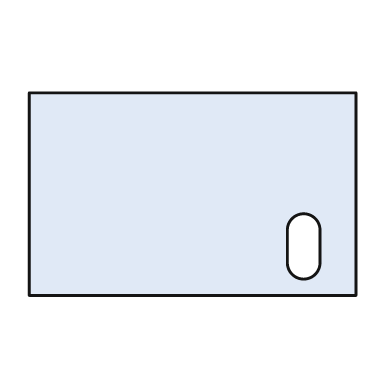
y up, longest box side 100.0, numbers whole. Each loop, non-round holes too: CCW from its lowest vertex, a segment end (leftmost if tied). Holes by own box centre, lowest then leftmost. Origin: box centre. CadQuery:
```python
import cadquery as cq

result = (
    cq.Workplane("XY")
    .moveTo(-50.0, -31.0)
    .lineTo(50.0, -31.0)
    .lineTo(50.0, 31.0)
    .lineTo(-50.0, 31.0)
    .close()
    .moveTo(29.0, -21.0)
    .threePointArc((34.0, -26.0), (39.0, -21.0))
    .lineTo(39.0, -11.0)
    .threePointArc((34.0, -6.0), (29.0, -11.0))
    .close()
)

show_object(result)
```